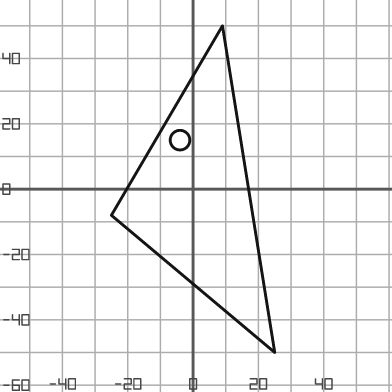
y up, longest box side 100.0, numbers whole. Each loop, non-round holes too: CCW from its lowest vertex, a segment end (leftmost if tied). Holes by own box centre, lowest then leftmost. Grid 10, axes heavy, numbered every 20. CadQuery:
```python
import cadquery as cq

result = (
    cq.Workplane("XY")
    .moveTo(25.0, -50.0)
    .lineTo(9.0, 50.0)
    .lineTo(-25.0, -8.0)
    .close()
    .moveTo(-4.0, 15.0)
    .circle(3.0)
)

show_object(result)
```